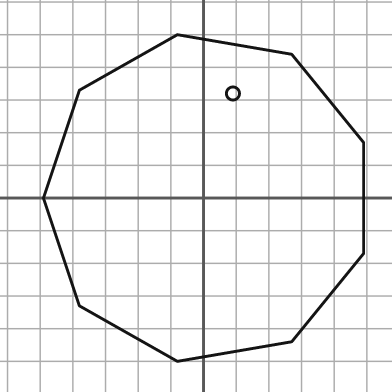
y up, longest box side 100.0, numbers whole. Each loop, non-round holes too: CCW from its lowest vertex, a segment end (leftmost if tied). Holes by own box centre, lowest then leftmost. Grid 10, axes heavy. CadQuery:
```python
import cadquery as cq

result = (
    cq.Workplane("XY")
    .moveTo(-8.0, -50.0)
    .lineTo(27.0, -44.0)
    .lineTo(49.0, -17.0)
    .lineTo(49.0, 17.0)
    .lineTo(27.0, 44.0)
    .lineTo(-8.0, 50.0)
    .lineTo(-38.0, 33.0)
    .lineTo(-49.0, 0.0)
    .lineTo(-38.0, -33.0)
    .close()
    .moveTo(9.0, 32.0)
    .circle(2.0)
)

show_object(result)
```